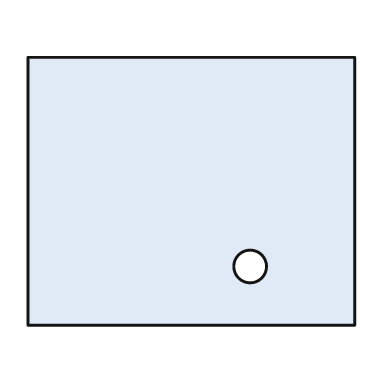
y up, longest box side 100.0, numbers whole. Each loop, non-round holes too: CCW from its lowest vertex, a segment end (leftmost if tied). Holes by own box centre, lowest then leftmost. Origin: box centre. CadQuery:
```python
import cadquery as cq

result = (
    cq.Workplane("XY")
    .moveTo(-50.0, -41.0)
    .lineTo(50.0, -41.0)
    .lineTo(50.0, 41.0)
    .lineTo(-50.0, 41.0)
    .close()
    .moveTo(18.0, -23.0)
    .circle(5.0)
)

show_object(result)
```